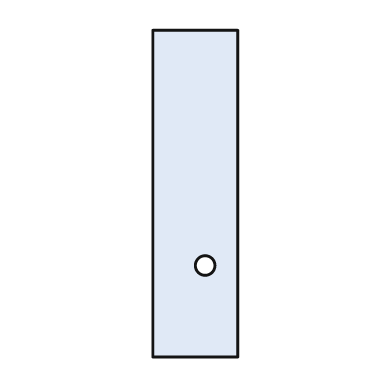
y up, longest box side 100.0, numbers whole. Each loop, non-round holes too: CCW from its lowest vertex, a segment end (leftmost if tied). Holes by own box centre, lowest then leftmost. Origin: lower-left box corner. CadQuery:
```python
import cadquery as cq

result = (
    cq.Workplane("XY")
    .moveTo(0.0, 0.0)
    .lineTo(26.0, 0.0)
    .lineTo(26.0, 100.0)
    .lineTo(0.0, 100.0)
    .close()
    .moveTo(16.0, 28.0)
    .circle(3.0)
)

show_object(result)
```